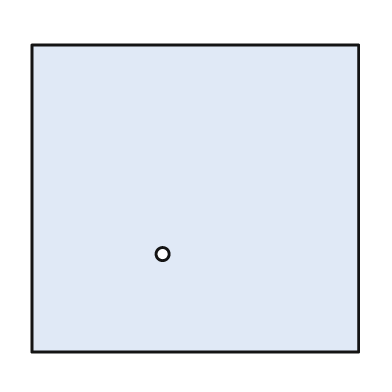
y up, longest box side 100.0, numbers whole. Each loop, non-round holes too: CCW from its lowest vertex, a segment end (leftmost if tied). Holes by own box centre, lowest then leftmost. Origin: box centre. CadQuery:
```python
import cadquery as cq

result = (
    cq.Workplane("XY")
    .moveTo(-50.0, -47.0)
    .lineTo(50.0, -47.0)
    .lineTo(50.0, 47.0)
    .lineTo(-50.0, 47.0)
    .close()
    .moveTo(-10.0, -17.0)
    .circle(2.0)
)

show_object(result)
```